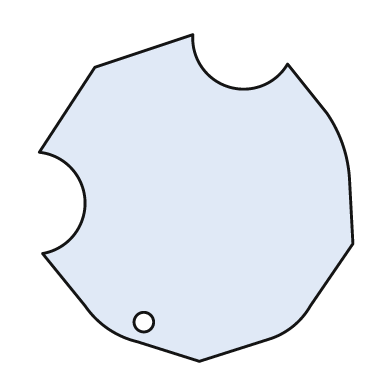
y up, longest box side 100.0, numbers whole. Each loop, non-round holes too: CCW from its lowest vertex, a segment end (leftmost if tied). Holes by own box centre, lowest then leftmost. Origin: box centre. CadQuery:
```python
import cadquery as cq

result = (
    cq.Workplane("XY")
    .moveTo(1.0, -50.0)
    .lineTo(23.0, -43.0)
    .threePointArc((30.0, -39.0), (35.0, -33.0))
    .lineTo(48.0, -14.0)
    .lineTo(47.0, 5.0)
    .threePointArc((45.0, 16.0), (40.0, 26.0))
    .lineTo(28.0, 41.0)
    .threePointArc((10.0, 34.0), (-1.0, 50.0))
    .lineTo(-31.0, 40.0)
    .lineTo(-48.0, 14.0)
    .threePointArc((-34.0, -1.0), (-47.0, -17.0))
    .lineTo(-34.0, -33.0)
    .threePointArc((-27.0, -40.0), (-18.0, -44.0))
    .close()
    .moveTo(-16.0, -38.0)
    .circle(3.0)
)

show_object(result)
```